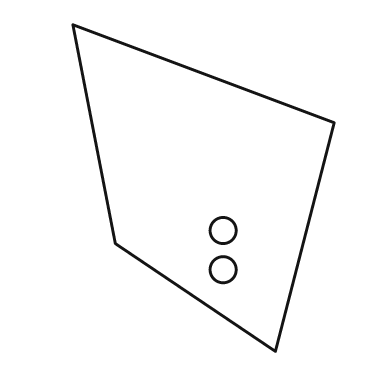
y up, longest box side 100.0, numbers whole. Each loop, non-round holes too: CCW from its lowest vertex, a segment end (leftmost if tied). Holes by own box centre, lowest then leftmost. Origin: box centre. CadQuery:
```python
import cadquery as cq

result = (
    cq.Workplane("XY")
    .moveTo(22.0, -50.0)
    .lineTo(40.0, 20.0)
    .lineTo(-40.0, 50.0)
    .lineTo(-27.0, -17.0)
    .close()
    .moveTo(6.0, -25.0)
    .circle(4.0)
    .moveTo(6.0, -13.0)
    .circle(4.0)
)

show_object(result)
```